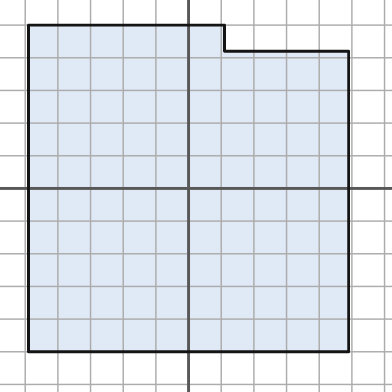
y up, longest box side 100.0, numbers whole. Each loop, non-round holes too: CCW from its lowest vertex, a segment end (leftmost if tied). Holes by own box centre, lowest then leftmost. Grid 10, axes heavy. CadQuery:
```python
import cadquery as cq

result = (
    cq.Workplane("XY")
    .moveTo(-49.0, -50.0)
    .lineTo(49.0, -50.0)
    .lineTo(49.0, 42.0)
    .lineTo(11.0, 42.0)
    .lineTo(11.0, 50.0)
    .lineTo(-49.0, 50.0)
    .close()
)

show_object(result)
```